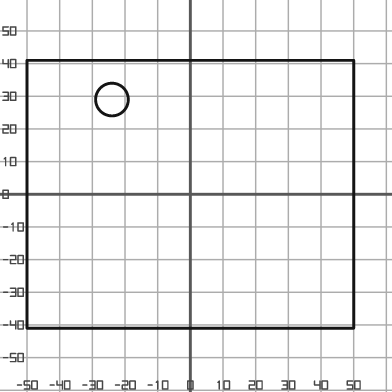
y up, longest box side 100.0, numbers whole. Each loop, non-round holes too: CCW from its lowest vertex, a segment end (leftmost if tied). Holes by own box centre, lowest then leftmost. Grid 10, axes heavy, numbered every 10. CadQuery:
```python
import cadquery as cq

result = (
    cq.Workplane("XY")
    .moveTo(-50.0, -41.0)
    .lineTo(50.0, -41.0)
    .lineTo(50.0, 41.0)
    .lineTo(-50.0, 41.0)
    .close()
    .moveTo(-24.0, 29.0)
    .circle(5.0)
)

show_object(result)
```